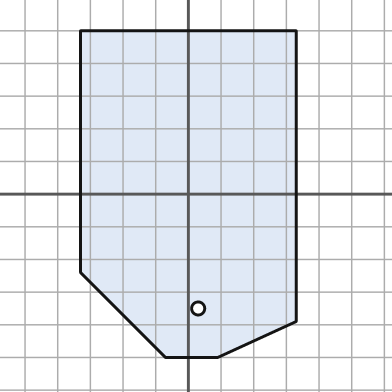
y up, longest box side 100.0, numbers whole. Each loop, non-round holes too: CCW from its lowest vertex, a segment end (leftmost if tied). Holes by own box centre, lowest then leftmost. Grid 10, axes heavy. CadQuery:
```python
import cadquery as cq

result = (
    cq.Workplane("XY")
    .moveTo(-7.0, -50.0)
    .lineTo(9.0, -50.0)
    .lineTo(33.0, -39.0)
    .lineTo(33.0, 50.0)
    .lineTo(-33.0, 50.0)
    .lineTo(-33.0, -24.0)
    .close()
    .moveTo(3.0, -35.0)
    .circle(2.0)
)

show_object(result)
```